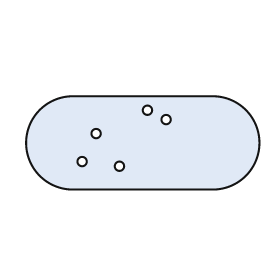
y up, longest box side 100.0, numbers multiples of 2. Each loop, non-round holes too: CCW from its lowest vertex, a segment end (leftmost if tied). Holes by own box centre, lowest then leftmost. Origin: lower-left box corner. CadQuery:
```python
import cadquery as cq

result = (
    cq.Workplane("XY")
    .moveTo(20.0, 0.0)
    .lineTo(80.0, 0.0)
    .threePointArc((100.0, 20.0), (80.0, 40.0))
    .lineTo(20.0, 40.0)
    .threePointArc((0.0, 20.0), (20.0, 0.0))
    .close()
    .moveTo(40.0, 10.0)
    .circle(2.0)
    .moveTo(24.0, 12.0)
    .circle(2.0)
    .moveTo(30.0, 24.0)
    .circle(2.0)
    .moveTo(60.0, 30.0)
    .circle(2.0)
    .moveTo(52.0, 34.0)
    .circle(2.0)
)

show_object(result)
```